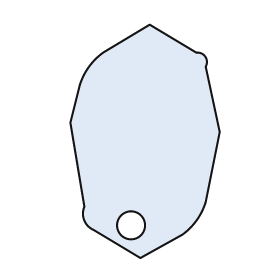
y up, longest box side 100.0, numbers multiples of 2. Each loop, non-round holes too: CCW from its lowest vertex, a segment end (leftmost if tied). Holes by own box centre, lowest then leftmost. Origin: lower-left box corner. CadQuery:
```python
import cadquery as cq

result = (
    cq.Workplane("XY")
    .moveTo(30.0, 0.0)
    .lineTo(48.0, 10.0)
    .threePointArc((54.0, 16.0), (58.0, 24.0))
    .lineTo(64.0, 54.0)
    .lineTo(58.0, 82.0)
    .threePointArc((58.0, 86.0), (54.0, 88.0))
    .lineTo(34.0, 100.0)
    .lineTo(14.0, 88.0)
    .threePointArc((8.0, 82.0), (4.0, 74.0))
    .lineTo(0.0, 58.0)
    .lineTo(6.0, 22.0)
    .threePointArc((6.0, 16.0), (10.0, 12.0))
    .close()
    .moveTo(26.0, 14.0)
    .circle(6.0)
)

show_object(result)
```